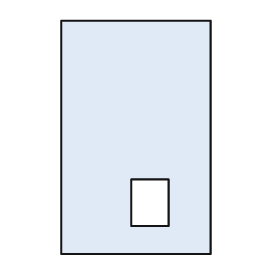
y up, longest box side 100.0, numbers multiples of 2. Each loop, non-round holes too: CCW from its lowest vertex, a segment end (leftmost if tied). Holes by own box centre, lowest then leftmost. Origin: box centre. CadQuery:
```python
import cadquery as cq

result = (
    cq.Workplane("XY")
    .moveTo(-32.0, -50.0)
    .lineTo(32.0, -50.0)
    .lineTo(32.0, 50.0)
    .lineTo(-32.0, 50.0)
    .close()
    .moveTo(-2.0, -38.0)
    .lineTo(14.0, -38.0)
    .lineTo(14.0, -18.0)
    .lineTo(-2.0, -18.0)
    .close()
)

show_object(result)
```